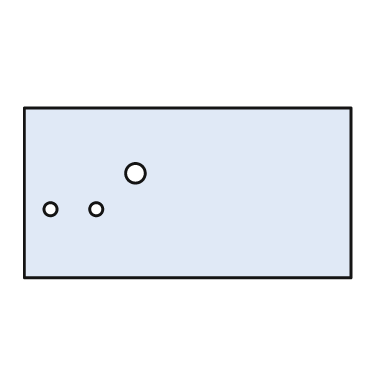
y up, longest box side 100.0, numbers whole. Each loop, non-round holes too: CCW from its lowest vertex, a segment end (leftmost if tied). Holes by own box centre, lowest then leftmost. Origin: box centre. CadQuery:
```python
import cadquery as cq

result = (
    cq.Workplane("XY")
    .moveTo(-50.0, -26.0)
    .lineTo(50.0, -26.0)
    .lineTo(50.0, 26.0)
    .lineTo(-50.0, 26.0)
    .close()
    .moveTo(-42.0, -5.0)
    .circle(2.0)
    .moveTo(-28.0, -5.0)
    .circle(2.0)
    .moveTo(-16.0, 6.0)
    .circle(3.0)
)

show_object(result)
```